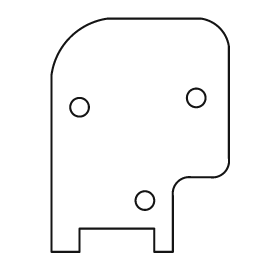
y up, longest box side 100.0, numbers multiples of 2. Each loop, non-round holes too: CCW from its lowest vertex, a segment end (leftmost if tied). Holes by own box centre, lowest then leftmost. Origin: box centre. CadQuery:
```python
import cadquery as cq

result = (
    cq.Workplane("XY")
    .moveTo(-38.0, -50.0)
    .lineTo(-26.0, -50.0)
    .lineTo(-26.0, -40.0)
    .lineTo(6.0, -40.0)
    .lineTo(6.0, -50.0)
    .lineTo(14.0, -50.0)
    .lineTo(14.0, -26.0)
    .threePointArc((16.0, -20.0), (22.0, -18.0))
    .lineTo(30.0, -18.0)
    .threePointArc((36.0, -16.0), (38.0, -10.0))
    .lineTo(38.0, 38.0)
    .threePointArc((34.0, 46.0), (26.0, 50.0))
    .lineTo(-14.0, 50.0)
    .threePointArc((-30.0, 42.0), (-38.0, 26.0))
    .close()
    .moveTo(2.0, -28.0)
    .circle(4.0)
    .moveTo(-26.0, 12.0)
    .circle(4.0)
    .moveTo(24.0, 16.0)
    .circle(4.0)
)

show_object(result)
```